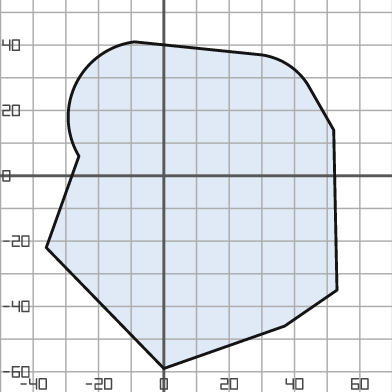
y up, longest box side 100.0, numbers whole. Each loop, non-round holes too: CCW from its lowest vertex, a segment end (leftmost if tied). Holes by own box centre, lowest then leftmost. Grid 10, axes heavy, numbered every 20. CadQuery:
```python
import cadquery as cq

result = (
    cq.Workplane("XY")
    .moveTo(0.0, -59.0)
    .lineTo(37.0, -46.0)
    .lineTo(53.0, -35.0)
    .lineTo(52.0, 14.0)
    .lineTo(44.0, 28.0)
    .threePointArc((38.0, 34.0), (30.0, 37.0))
    .lineTo(-9.0, 41.0)
    .threePointArc((-27.0, 28.0), (-26.0, 6.0))
    .lineTo(-36.0, -22.0)
    .close()
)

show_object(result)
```